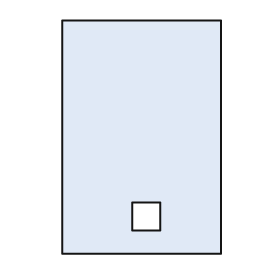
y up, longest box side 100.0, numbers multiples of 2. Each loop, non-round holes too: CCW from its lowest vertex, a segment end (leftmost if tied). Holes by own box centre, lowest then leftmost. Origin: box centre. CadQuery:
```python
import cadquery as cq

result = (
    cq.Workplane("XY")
    .moveTo(-34.0, -50.0)
    .lineTo(34.0, -50.0)
    .lineTo(34.0, 50.0)
    .lineTo(-34.0, 50.0)
    .close()
    .moveTo(-4.0, -40.0)
    .lineTo(8.0, -40.0)
    .lineTo(8.0, -28.0)
    .lineTo(-4.0, -28.0)
    .close()
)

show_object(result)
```